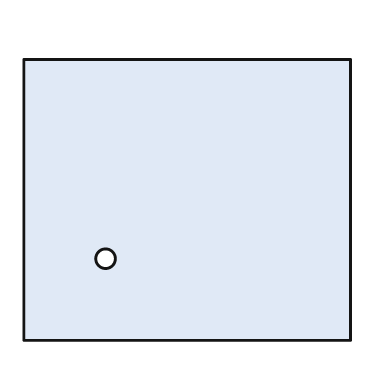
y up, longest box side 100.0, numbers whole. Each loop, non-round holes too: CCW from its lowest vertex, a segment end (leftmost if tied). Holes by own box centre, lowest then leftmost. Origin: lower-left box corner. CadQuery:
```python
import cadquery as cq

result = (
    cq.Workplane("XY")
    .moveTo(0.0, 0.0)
    .lineTo(100.0, 0.0)
    .lineTo(100.0, 86.0)
    .lineTo(0.0, 86.0)
    .close()
    .moveTo(25.0, 25.0)
    .circle(3.0)
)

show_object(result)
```